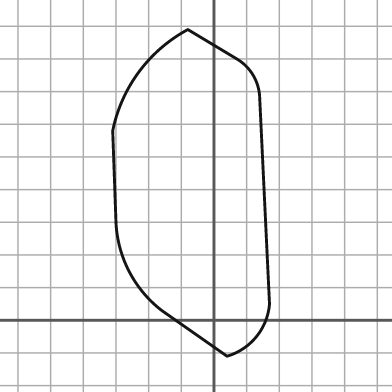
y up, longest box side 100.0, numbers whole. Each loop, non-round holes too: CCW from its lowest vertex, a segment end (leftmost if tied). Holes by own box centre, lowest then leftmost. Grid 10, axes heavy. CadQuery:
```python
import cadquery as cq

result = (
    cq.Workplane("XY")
    .moveTo(4.0, -11.0)
    .threePointArc((13.0, -5.0), (17.0, 5.0))
    .lineTo(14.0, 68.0)
    .threePointArc((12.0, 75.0), (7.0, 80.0))
    .lineTo(-8.0, 89.0)
    .threePointArc((-23.0, 76.0), (-31.0, 58.0))
    .lineTo(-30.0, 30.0)
    .threePointArc((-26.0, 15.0), (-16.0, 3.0))
    .close()
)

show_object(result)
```